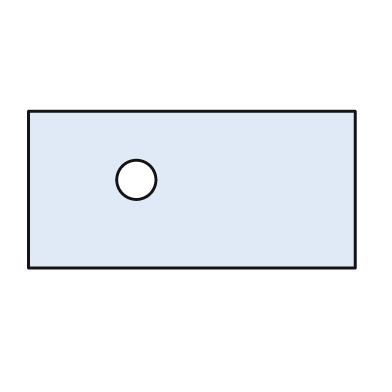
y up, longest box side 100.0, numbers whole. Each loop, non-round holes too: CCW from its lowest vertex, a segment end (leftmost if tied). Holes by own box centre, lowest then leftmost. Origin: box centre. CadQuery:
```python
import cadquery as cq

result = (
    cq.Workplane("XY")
    .moveTo(-50.0, -24.0)
    .lineTo(50.0, -24.0)
    .lineTo(50.0, 24.0)
    .lineTo(-50.0, 24.0)
    .close()
    .moveTo(-17.0, 3.0)
    .circle(6.0)
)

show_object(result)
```